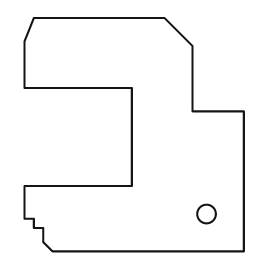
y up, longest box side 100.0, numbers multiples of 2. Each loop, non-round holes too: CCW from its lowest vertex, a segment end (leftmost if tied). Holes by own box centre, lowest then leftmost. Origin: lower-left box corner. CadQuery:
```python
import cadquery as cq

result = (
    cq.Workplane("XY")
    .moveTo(12.0, 0.0)
    .lineTo(94.0, 0.0)
    .lineTo(94.0, 60.0)
    .lineTo(72.0, 60.0)
    .lineTo(72.0, 88.0)
    .lineTo(60.0, 100.0)
    .lineTo(4.0, 100.0)
    .lineTo(0.0, 90.0)
    .lineTo(0.0, 70.0)
    .lineTo(46.0, 70.0)
    .lineTo(46.0, 28.0)
    .lineTo(0.0, 28.0)
    .lineTo(0.0, 14.0)
    .lineTo(4.0, 14.0)
    .lineTo(4.0, 10.0)
    .lineTo(8.0, 10.0)
    .lineTo(8.0, 4.0)
    .close()
    .moveTo(78.0, 16.0)
    .circle(4.0)
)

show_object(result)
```